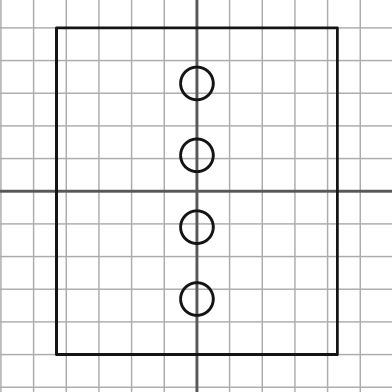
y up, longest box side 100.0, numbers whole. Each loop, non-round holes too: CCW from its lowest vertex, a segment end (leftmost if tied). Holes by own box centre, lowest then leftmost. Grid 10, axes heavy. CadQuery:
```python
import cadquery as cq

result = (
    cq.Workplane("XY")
    .moveTo(-43.0, -50.0)
    .lineTo(43.0, -50.0)
    .lineTo(43.0, 50.0)
    .lineTo(-43.0, 50.0)
    .close()
    .moveTo(0.0, -33.0)
    .circle(5.0)
    .moveTo(0.0, -11.0)
    .circle(5.0)
    .moveTo(0.0, 11.0)
    .circle(5.0)
    .moveTo(0.0, 33.0)
    .circle(5.0)
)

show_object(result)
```